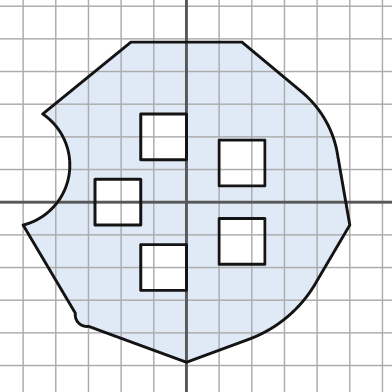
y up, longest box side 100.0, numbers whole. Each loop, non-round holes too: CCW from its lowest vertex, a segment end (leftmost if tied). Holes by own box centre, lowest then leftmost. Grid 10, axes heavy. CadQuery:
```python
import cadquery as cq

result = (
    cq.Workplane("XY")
    .moveTo(0.0, -49.0)
    .lineTo(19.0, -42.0)
    .threePointArc((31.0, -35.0), (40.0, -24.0))
    .lineTo(50.0, -7.0)
    .lineTo(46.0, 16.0)
    .threePointArc((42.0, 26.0), (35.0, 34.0))
    .lineTo(17.0, 49.0)
    .lineTo(-17.0, 49.0)
    .lineTo(-44.0, 27.0)
    .threePointArc((-36.0, 8.0), (-50.0, -7.0))
    .lineTo(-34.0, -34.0)
    .threePointArc((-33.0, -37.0), (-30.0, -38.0))
    .close()
    .moveTo(-14.0, -27.0)
    .lineTo(0.0, -27.0)
    .lineTo(0.0, -13.0)
    .lineTo(-14.0, -13.0)
    .close()
    .moveTo(10.0, -19.0)
    .lineTo(24.0, -19.0)
    .lineTo(24.0, -5.0)
    .lineTo(10.0, -5.0)
    .close()
    .moveTo(-28.0, -7.0)
    .lineTo(-14.0, -7.0)
    .lineTo(-14.0, 7.0)
    .lineTo(-28.0, 7.0)
    .close()
    .moveTo(10.0, 5.0)
    .lineTo(24.0, 5.0)
    .lineTo(24.0, 19.0)
    .lineTo(10.0, 19.0)
    .close()
    .moveTo(-14.0, 13.0)
    .lineTo(0.0, 13.0)
    .lineTo(0.0, 27.0)
    .lineTo(-14.0, 27.0)
    .close()
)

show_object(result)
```